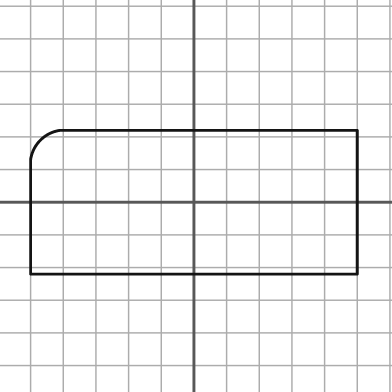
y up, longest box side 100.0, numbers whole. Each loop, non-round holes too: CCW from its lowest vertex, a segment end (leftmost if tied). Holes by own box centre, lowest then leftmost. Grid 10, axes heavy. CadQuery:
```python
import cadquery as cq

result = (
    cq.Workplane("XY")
    .moveTo(-50.0, -22.0)
    .lineTo(50.0, -22.0)
    .lineTo(50.0, 22.0)
    .lineTo(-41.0, 22.0)
    .threePointArc((-47.0, 19.0), (-50.0, 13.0))
    .close()
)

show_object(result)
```